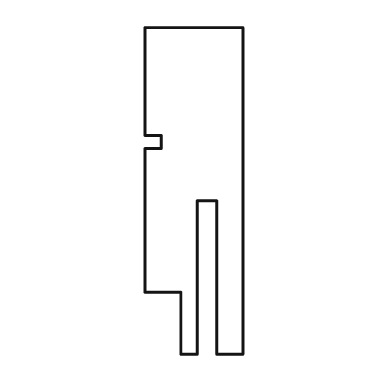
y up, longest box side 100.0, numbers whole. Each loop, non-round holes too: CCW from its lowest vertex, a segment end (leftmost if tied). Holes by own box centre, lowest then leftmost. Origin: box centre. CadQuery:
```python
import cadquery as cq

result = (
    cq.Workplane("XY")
    .moveTo(-4.0, -50.0)
    .lineTo(1.0, -50.0)
    .lineTo(1.0, -3.0)
    .lineTo(7.0, -3.0)
    .lineTo(7.0, -50.0)
    .lineTo(15.0, -50.0)
    .lineTo(15.0, 50.0)
    .lineTo(-15.0, 50.0)
    .lineTo(-15.0, 17.0)
    .lineTo(-10.0, 17.0)
    .lineTo(-10.0, 13.0)
    .lineTo(-15.0, 13.0)
    .lineTo(-15.0, -31.0)
    .lineTo(-4.0, -31.0)
    .close()
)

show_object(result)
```